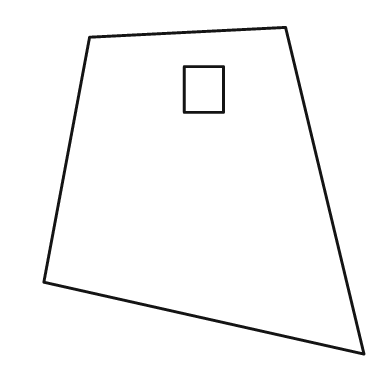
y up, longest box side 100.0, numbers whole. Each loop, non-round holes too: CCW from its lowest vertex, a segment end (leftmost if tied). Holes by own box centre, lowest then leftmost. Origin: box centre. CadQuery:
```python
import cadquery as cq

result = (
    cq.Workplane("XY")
    .moveTo(49.0, -50.0)
    .lineTo(25.0, 50.0)
    .lineTo(-35.0, 47.0)
    .lineTo(-49.0, -28.0)
    .close()
    .moveTo(-6.0, 24.0)
    .lineTo(6.0, 24.0)
    .lineTo(6.0, 38.0)
    .lineTo(-6.0, 38.0)
    .close()
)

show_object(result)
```